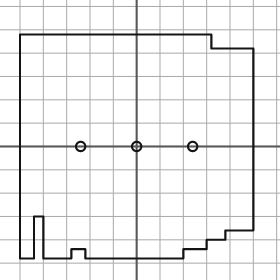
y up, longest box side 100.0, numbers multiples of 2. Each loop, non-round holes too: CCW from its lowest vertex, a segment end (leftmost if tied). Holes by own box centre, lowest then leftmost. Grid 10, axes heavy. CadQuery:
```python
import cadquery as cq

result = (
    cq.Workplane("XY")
    .moveTo(-50.0, -48.0)
    .lineTo(-44.0, -48.0)
    .lineTo(-44.0, -30.0)
    .lineTo(-40.0, -30.0)
    .lineTo(-40.0, -48.0)
    .lineTo(-28.0, -48.0)
    .lineTo(-28.0, -44.0)
    .lineTo(-22.0, -44.0)
    .lineTo(-22.0, -48.0)
    .lineTo(20.0, -48.0)
    .lineTo(20.0, -44.0)
    .lineTo(30.0, -44.0)
    .lineTo(30.0, -40.0)
    .lineTo(38.0, -40.0)
    .lineTo(38.0, -36.0)
    .lineTo(50.0, -36.0)
    .lineTo(50.0, 42.0)
    .lineTo(32.0, 42.0)
    .lineTo(32.0, 48.0)
    .lineTo(-50.0, 48.0)
    .close()
    .moveTo(-24.0, 0.0)
    .circle(2.0)
    .moveTo(0.0, 0.0)
    .circle(2.0)
    .moveTo(24.0, 0.0)
    .circle(2.0)
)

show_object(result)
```